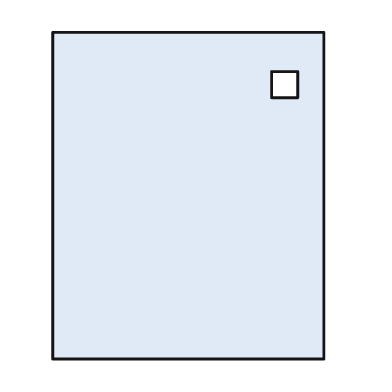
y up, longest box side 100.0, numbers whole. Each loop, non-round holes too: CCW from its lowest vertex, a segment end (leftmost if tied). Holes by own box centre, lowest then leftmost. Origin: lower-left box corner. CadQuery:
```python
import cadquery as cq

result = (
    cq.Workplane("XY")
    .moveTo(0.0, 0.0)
    .lineTo(83.0, 0.0)
    .lineTo(83.0, 100.0)
    .lineTo(0.0, 100.0)
    .close()
    .moveTo(67.0, 80.0)
    .lineTo(75.0, 80.0)
    .lineTo(75.0, 88.0)
    .lineTo(67.0, 88.0)
    .close()
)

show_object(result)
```